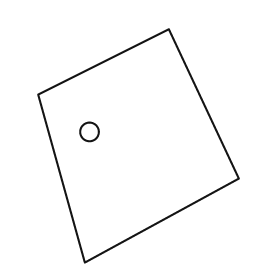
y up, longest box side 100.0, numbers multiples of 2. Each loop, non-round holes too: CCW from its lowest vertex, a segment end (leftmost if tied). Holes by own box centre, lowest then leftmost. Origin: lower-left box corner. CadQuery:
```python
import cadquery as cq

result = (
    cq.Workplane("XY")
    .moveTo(20.0, 0.0)
    .lineTo(86.0, 36.0)
    .lineTo(56.0, 100.0)
    .lineTo(0.0, 72.0)
    .close()
    .moveTo(22.0, 56.0)
    .circle(4.0)
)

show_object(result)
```